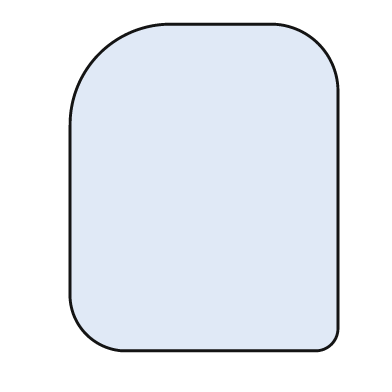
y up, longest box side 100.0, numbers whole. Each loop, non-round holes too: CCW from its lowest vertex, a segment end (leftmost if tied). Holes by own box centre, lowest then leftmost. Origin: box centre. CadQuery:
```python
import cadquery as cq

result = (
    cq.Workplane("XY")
    .moveTo(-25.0, -50.0)
    .lineTo(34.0, -50.0)
    .threePointArc((39.0, -48.0), (41.0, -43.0))
    .lineTo(41.0, 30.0)
    .threePointArc((35.0, 44.0), (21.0, 50.0))
    .lineTo(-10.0, 50.0)
    .threePointArc((-32.0, 41.0), (-41.0, 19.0))
    .lineTo(-41.0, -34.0)
    .threePointArc((-36.0, -45.0), (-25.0, -50.0))
    .close()
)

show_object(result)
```